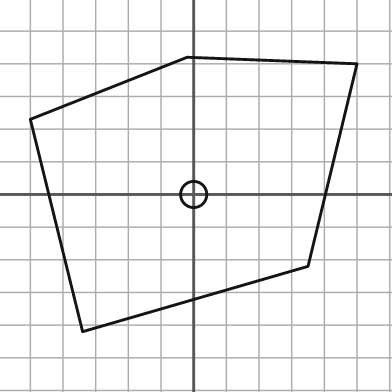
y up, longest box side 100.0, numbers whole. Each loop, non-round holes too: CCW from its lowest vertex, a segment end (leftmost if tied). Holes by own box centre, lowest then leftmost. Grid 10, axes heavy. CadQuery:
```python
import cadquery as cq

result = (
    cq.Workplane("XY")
    .moveTo(-34.0, -42.0)
    .lineTo(35.0, -22.0)
    .lineTo(50.0, 40.0)
    .lineTo(-2.0, 42.0)
    .lineTo(-50.0, 23.0)
    .close()
    .moveTo(0.0, 0.0)
    .circle(4.0)
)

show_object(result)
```